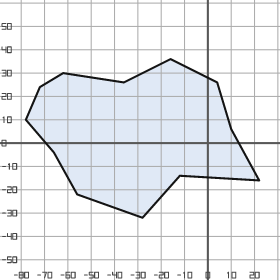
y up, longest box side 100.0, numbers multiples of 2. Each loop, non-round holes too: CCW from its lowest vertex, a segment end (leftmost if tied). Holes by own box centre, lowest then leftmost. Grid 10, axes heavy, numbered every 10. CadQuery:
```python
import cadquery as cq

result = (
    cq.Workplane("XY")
    .moveTo(-28.0, -32.0)
    .lineTo(-12.0, -14.0)
    .lineTo(22.0, -16.0)
    .lineTo(10.0, 6.0)
    .lineTo(4.0, 26.0)
    .lineTo(-16.0, 36.0)
    .lineTo(-36.0, 26.0)
    .lineTo(-62.0, 30.0)
    .lineTo(-72.0, 24.0)
    .lineTo(-78.0, 10.0)
    .lineTo(-66.0, -4.0)
    .lineTo(-56.0, -22.0)
    .close()
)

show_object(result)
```